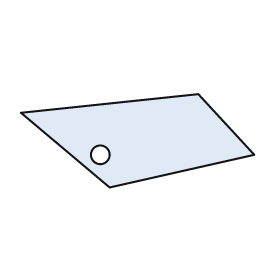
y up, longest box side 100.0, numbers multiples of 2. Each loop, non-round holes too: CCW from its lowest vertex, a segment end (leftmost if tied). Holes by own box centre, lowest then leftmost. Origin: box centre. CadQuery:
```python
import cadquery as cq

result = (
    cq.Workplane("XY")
    .moveTo(-12.0, -20.0)
    .lineTo(50.0, -6.0)
    .lineTo(26.0, 20.0)
    .lineTo(-50.0, 12.0)
    .close()
    .moveTo(-16.0, -6.0)
    .circle(4.0)
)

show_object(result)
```